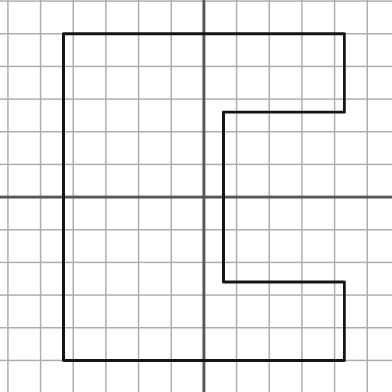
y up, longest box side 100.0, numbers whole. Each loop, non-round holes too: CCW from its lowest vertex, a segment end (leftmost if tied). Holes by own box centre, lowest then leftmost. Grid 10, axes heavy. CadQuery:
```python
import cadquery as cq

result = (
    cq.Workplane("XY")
    .moveTo(-43.0, -50.0)
    .lineTo(43.0, -50.0)
    .lineTo(43.0, -26.0)
    .lineTo(6.0, -26.0)
    .lineTo(6.0, 26.0)
    .lineTo(43.0, 26.0)
    .lineTo(43.0, 50.0)
    .lineTo(-43.0, 50.0)
    .close()
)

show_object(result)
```